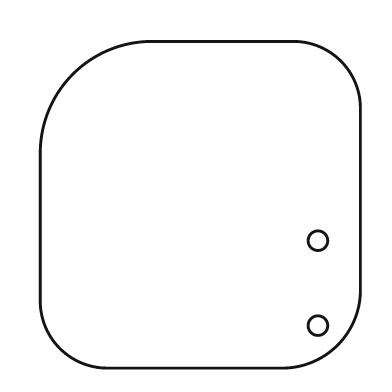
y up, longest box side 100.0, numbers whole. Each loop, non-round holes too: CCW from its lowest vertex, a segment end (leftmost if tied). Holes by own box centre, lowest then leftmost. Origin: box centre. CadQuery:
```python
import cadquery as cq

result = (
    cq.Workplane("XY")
    .moveTo(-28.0, -50.0)
    .lineTo(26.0, -50.0)
    .threePointArc((42.0, -43.0), (49.0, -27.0))
    .lineTo(49.0, 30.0)
    .threePointArc((43.0, 44.0), (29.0, 50.0))
    .lineTo(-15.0, 50.0)
    .threePointArc((-39.0, 40.0), (-49.0, 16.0))
    .lineTo(-49.0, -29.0)
    .threePointArc((-43.0, -44.0), (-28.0, -50.0))
    .close()
    .moveTo(36.0, -37.0)
    .circle(3.0)
    .moveTo(36.0, -11.0)
    .circle(3.0)
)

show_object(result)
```